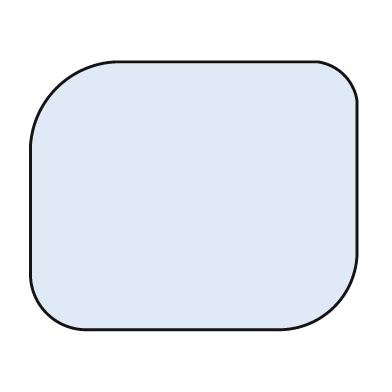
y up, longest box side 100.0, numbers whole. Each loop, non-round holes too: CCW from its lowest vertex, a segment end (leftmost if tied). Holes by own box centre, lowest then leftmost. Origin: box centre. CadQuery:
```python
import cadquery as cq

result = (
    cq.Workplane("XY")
    .moveTo(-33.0, -41.0)
    .lineTo(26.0, -41.0)
    .threePointArc((43.0, -34.0), (50.0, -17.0))
    .lineTo(50.0, 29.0)
    .threePointArc((46.0, 37.0), (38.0, 41.0))
    .lineTo(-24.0, 41.0)
    .threePointArc((-42.0, 33.0), (-50.0, 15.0))
    .lineTo(-50.0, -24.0)
    .threePointArc((-45.0, -36.0), (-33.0, -41.0))
    .close()
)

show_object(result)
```